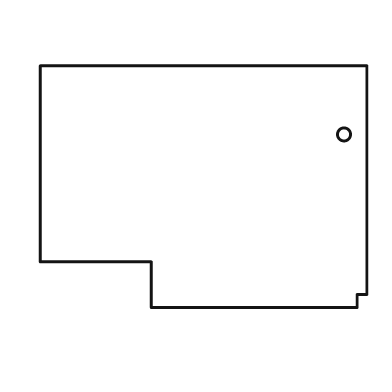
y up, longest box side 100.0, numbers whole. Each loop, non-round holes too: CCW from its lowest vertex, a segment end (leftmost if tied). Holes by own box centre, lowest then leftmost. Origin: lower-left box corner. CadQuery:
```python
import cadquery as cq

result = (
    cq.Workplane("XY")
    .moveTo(34.0, 0.0)
    .lineTo(97.0, 0.0)
    .lineTo(97.0, 4.0)
    .lineTo(100.0, 4.0)
    .lineTo(100.0, 74.0)
    .lineTo(0.0, 74.0)
    .lineTo(0.0, 14.0)
    .lineTo(34.0, 14.0)
    .close()
    .moveTo(93.0, 53.0)
    .circle(2.0)
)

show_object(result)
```